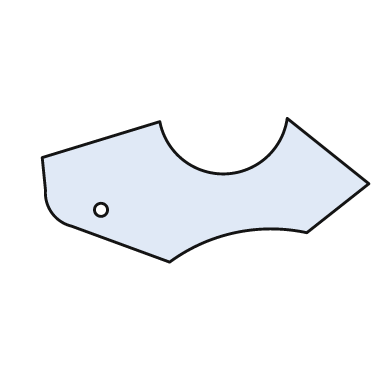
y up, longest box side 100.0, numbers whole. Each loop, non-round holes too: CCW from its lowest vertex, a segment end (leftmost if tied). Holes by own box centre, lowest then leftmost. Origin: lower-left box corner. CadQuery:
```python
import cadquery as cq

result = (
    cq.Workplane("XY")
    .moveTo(39.0, 0.0)
    .threePointArc((59.0, 9.0), (81.0, 9.0))
    .lineTo(100.0, 24.0)
    .lineTo(75.0, 44.0)
    .threePointArc((56.0, 27.0), (36.0, 43.0))
    .lineTo(0.0, 32.0)
    .lineTo(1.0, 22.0)
    .threePointArc((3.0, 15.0), (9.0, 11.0))
    .close()
    .moveTo(18.0, 16.0)
    .circle(2.0)
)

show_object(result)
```